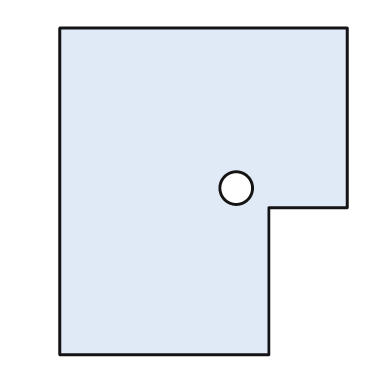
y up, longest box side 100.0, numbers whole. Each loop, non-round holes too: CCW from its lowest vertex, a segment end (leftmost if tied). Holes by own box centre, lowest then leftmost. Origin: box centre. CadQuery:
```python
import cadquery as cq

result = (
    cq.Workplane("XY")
    .moveTo(-44.0, -50.0)
    .lineTo(20.0, -50.0)
    .lineTo(20.0, -5.0)
    .lineTo(44.0, -5.0)
    .lineTo(44.0, 50.0)
    .lineTo(-44.0, 50.0)
    .close()
    .moveTo(10.0, 1.0)
    .circle(5.0)
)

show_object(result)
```